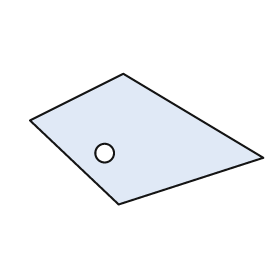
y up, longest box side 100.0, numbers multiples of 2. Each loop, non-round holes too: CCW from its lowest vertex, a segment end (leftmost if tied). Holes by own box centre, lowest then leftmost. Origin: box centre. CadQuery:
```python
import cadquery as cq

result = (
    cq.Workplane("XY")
    .moveTo(-12.0, -28.0)
    .lineTo(50.0, -8.0)
    .lineTo(-10.0, 28.0)
    .lineTo(-50.0, 8.0)
    .close()
    .moveTo(-18.0, -6.0)
    .circle(4.0)
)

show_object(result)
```